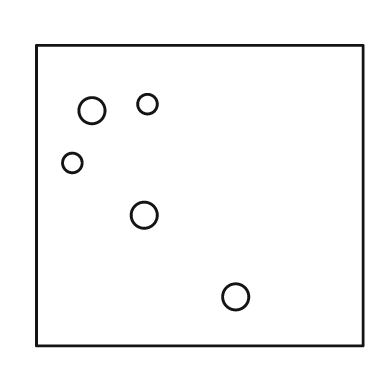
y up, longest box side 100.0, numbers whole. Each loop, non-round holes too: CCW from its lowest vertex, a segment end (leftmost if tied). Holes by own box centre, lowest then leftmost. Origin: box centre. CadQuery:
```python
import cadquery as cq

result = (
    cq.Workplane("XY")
    .moveTo(-50.0, -46.0)
    .lineTo(50.0, -46.0)
    .lineTo(50.0, 46.0)
    .lineTo(-50.0, 46.0)
    .close()
    .moveTo(11.0, -31.0)
    .circle(4.0)
    .moveTo(-17.0, -6.0)
    .circle(4.0)
    .moveTo(-39.0, 10.0)
    .circle(3.0)
    .moveTo(-33.0, 26.0)
    .circle(4.0)
    .moveTo(-16.0, 28.0)
    .circle(3.0)
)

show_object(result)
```